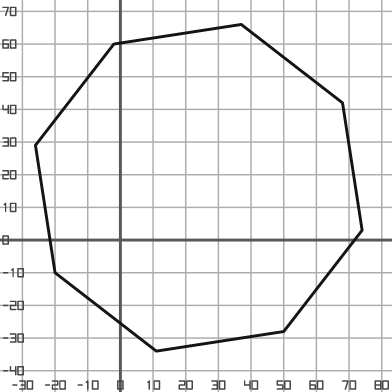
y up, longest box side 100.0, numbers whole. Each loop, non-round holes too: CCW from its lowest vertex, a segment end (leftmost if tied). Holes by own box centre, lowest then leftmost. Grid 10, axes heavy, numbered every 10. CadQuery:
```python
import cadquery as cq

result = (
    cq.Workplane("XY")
    .moveTo(11.0, -34.0)
    .lineTo(50.0, -28.0)
    .lineTo(74.0, 3.0)
    .lineTo(68.0, 42.0)
    .lineTo(37.0, 66.0)
    .lineTo(-2.0, 60.0)
    .lineTo(-26.0, 29.0)
    .lineTo(-20.0, -10.0)
    .close()
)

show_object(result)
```